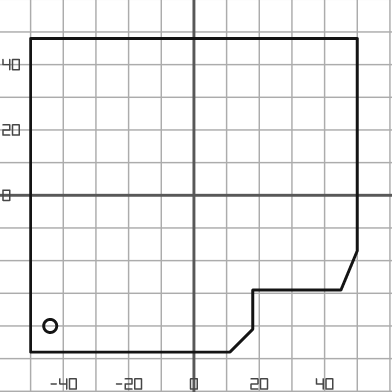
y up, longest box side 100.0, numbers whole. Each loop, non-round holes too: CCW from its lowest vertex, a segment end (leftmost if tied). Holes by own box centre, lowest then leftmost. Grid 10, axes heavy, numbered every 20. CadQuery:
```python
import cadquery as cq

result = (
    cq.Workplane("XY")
    .moveTo(-50.0, -48.0)
    .lineTo(11.0, -48.0)
    .lineTo(18.0, -41.0)
    .lineTo(18.0, -29.0)
    .lineTo(45.0, -29.0)
    .lineTo(50.0, -17.0)
    .lineTo(50.0, 48.0)
    .lineTo(-50.0, 48.0)
    .close()
    .moveTo(-44.0, -40.0)
    .circle(2.0)
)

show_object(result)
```